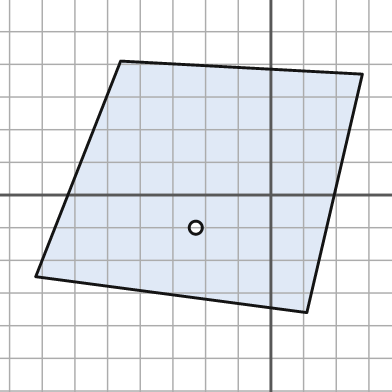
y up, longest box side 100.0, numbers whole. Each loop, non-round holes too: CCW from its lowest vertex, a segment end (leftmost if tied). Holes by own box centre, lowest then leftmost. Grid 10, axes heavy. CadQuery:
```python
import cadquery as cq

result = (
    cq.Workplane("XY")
    .moveTo(11.0, -36.0)
    .lineTo(28.0, 37.0)
    .lineTo(-46.0, 41.0)
    .lineTo(-72.0, -25.0)
    .close()
    .moveTo(-23.0, -10.0)
    .circle(2.0)
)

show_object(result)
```